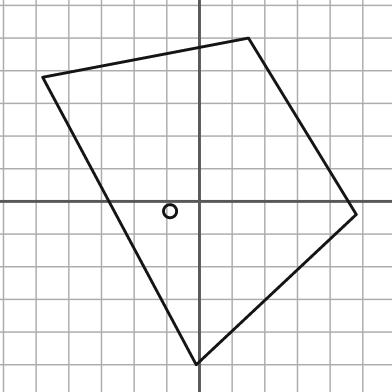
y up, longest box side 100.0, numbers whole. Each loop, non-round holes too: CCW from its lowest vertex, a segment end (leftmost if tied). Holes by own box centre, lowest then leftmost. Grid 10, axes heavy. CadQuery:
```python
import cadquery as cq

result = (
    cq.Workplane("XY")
    .moveTo(-1.0, -50.0)
    .lineTo(48.0, -4.0)
    .lineTo(15.0, 50.0)
    .lineTo(-48.0, 38.0)
    .close()
    .moveTo(-9.0, -3.0)
    .circle(2.0)
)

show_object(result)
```